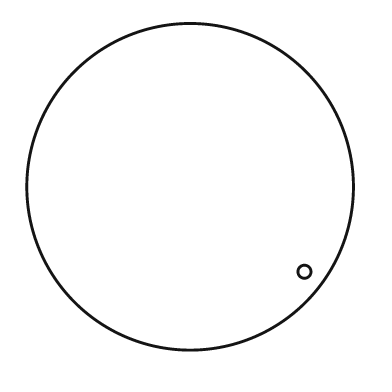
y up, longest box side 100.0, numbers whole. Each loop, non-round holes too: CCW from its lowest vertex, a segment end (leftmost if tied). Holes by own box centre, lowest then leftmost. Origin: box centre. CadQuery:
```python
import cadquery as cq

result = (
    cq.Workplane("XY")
    .moveTo(0.0, 0.0)
    .circle(50.0)
    .moveTo(35.0, -26.0)
    .circle(2.0)
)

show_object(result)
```